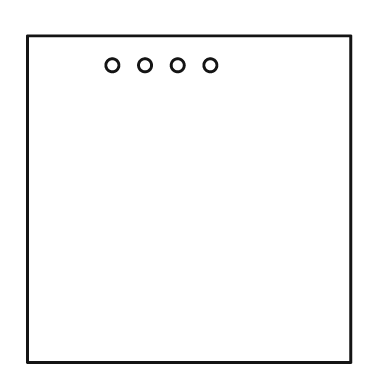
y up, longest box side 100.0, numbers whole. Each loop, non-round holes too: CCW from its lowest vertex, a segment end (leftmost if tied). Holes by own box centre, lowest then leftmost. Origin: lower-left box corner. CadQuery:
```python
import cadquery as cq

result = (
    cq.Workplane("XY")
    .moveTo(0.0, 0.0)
    .lineTo(99.0, 0.0)
    .lineTo(99.0, 100.0)
    .lineTo(0.0, 100.0)
    .close()
    .moveTo(26.0, 91.0)
    .circle(2.0)
    .moveTo(36.0, 91.0)
    .circle(2.0)
    .moveTo(46.0, 91.0)
    .circle(2.0)
    .moveTo(56.0, 91.0)
    .circle(2.0)
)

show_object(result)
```